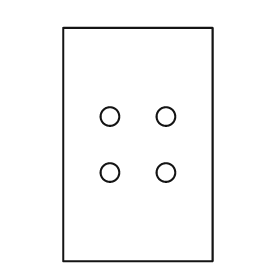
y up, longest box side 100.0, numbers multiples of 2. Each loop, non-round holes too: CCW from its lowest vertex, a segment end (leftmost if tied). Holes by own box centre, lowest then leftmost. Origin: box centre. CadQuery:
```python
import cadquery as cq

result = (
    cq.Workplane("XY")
    .moveTo(-32.0, -50.0)
    .lineTo(32.0, -50.0)
    .lineTo(32.0, 50.0)
    .lineTo(-32.0, 50.0)
    .close()
    .moveTo(-12.0, -12.0)
    .circle(4.0)
    .moveTo(12.0, -12.0)
    .circle(4.0)
    .moveTo(-12.0, 12.0)
    .circle(4.0)
    .moveTo(12.0, 12.0)
    .circle(4.0)
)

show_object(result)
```